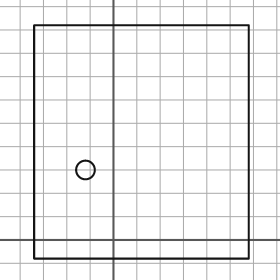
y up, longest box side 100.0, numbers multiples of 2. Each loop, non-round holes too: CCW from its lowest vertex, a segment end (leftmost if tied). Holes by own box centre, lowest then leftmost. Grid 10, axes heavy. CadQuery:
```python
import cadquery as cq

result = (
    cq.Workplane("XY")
    .moveTo(-34.0, -8.0)
    .lineTo(58.0, -8.0)
    .lineTo(58.0, 92.0)
    .lineTo(-34.0, 92.0)
    .close()
    .moveTo(-12.0, 30.0)
    .circle(4.0)
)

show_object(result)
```